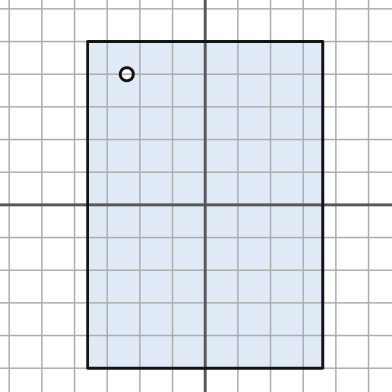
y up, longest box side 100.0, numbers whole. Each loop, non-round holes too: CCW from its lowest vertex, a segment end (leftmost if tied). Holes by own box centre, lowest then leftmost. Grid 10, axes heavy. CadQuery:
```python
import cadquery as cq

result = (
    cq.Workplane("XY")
    .moveTo(-36.0, -50.0)
    .lineTo(36.0, -50.0)
    .lineTo(36.0, 50.0)
    .lineTo(-36.0, 50.0)
    .close()
    .moveTo(-24.0, 40.0)
    .circle(2.0)
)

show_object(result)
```